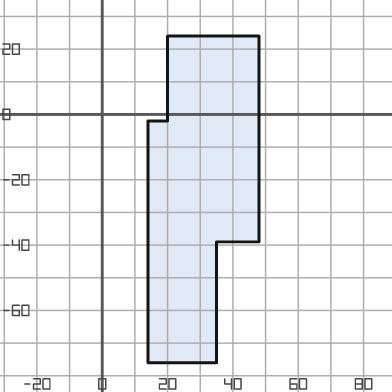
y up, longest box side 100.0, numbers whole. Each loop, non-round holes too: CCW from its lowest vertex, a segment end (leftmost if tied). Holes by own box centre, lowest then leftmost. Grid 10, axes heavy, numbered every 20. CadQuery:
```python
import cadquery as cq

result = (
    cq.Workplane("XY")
    .moveTo(14.0, -76.0)
    .lineTo(35.0, -76.0)
    .lineTo(35.0, -39.0)
    .lineTo(48.0, -39.0)
    .lineTo(48.0, 24.0)
    .lineTo(20.0, 24.0)
    .lineTo(20.0, -2.0)
    .lineTo(14.0, -2.0)
    .close()
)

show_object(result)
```